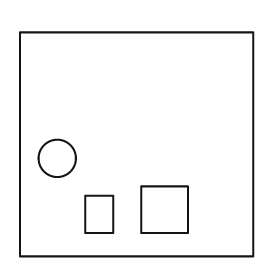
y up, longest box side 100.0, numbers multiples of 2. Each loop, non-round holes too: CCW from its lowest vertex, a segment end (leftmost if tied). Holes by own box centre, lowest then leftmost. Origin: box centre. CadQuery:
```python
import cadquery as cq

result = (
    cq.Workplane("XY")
    .moveTo(-50.0, -48.0)
    .lineTo(50.0, -48.0)
    .lineTo(50.0, 48.0)
    .lineTo(-50.0, 48.0)
    .close()
    .moveTo(-22.0, -38.0)
    .lineTo(-10.0, -38.0)
    .lineTo(-10.0, -22.0)
    .lineTo(-22.0, -22.0)
    .close()
    .moveTo(2.0, -38.0)
    .lineTo(22.0, -38.0)
    .lineTo(22.0, -18.0)
    .lineTo(2.0, -18.0)
    .close()
    .moveTo(-34.0, -6.0)
    .circle(8.0)
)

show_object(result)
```